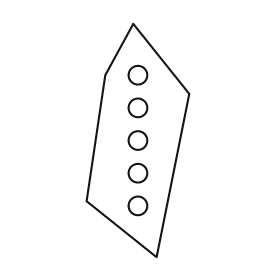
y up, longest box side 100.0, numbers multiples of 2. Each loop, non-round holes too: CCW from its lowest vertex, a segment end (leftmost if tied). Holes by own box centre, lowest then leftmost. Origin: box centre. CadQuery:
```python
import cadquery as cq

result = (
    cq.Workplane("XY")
    .moveTo(8.0, -50.0)
    .lineTo(22.0, 20.0)
    .lineTo(-2.0, 50.0)
    .lineTo(-14.0, 28.0)
    .lineTo(-22.0, -26.0)
    .close()
    .moveTo(0.0, -28.0)
    .circle(4.0)
    .moveTo(0.0, -14.0)
    .circle(4.0)
    .moveTo(0.0, 0.0)
    .circle(4.0)
    .moveTo(0.0, 14.0)
    .circle(4.0)
    .moveTo(0.0, 28.0)
    .circle(4.0)
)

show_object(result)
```